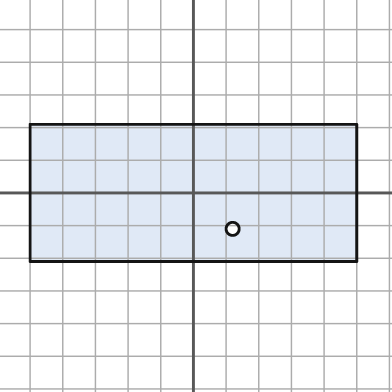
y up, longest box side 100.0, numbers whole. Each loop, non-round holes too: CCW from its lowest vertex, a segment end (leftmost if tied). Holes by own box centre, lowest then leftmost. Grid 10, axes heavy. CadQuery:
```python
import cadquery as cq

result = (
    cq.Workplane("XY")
    .moveTo(-50.0, -21.0)
    .lineTo(50.0, -21.0)
    .lineTo(50.0, 21.0)
    .lineTo(-50.0, 21.0)
    .close()
    .moveTo(12.0, -11.0)
    .circle(2.0)
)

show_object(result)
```